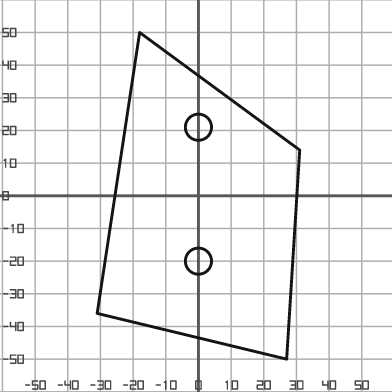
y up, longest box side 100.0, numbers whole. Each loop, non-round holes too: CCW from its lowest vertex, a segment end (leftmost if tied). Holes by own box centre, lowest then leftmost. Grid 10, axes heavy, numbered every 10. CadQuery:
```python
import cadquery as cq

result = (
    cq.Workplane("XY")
    .moveTo(27.0, -50.0)
    .lineTo(31.0, 14.0)
    .lineTo(-18.0, 50.0)
    .lineTo(-31.0, -36.0)
    .close()
    .moveTo(0.0, -20.0)
    .circle(4.0)
    .moveTo(0.0, 21.0)
    .circle(4.0)
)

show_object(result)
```